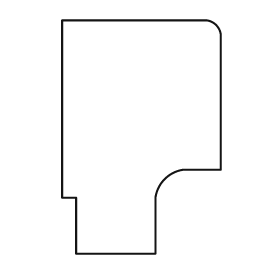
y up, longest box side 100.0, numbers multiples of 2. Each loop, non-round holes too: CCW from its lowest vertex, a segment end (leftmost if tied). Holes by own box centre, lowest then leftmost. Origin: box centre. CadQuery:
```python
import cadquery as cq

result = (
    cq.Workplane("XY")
    .moveTo(-28.0, -50.0)
    .lineTo(6.0, -50.0)
    .lineTo(6.0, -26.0)
    .threePointArc((10.0, -18.0), (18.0, -14.0))
    .lineTo(34.0, -14.0)
    .lineTo(34.0, 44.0)
    .threePointArc((32.0, 48.0), (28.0, 50.0))
    .lineTo(-34.0, 50.0)
    .lineTo(-34.0, -26.0)
    .lineTo(-28.0, -26.0)
    .close()
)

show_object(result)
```